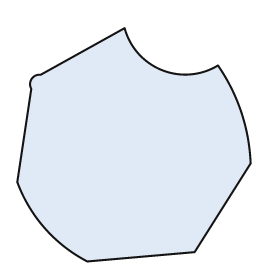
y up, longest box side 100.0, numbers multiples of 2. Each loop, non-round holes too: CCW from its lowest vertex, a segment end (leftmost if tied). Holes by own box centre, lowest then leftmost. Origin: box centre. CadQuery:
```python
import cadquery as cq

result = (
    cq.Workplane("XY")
    .moveTo(-20.0, -50.0)
    .lineTo(26.0, -46.0)
    .lineTo(50.0, -8.0)
    .threePointArc((46.0, 14.0), (36.0, 34.0))
    .threePointArc((12.0, 32.0), (-4.0, 50.0))
    .lineTo(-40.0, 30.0)
    .threePointArc((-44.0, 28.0), (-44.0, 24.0))
    .lineTo(-50.0, -16.0)
    .threePointArc((-38.0, -36.0), (-20.0, -50.0))
    .close()
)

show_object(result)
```